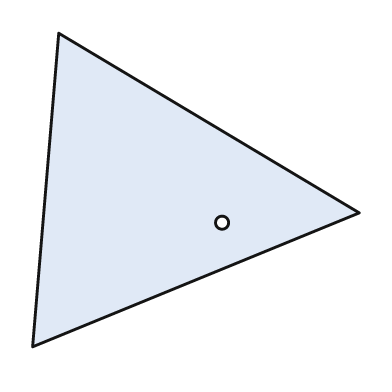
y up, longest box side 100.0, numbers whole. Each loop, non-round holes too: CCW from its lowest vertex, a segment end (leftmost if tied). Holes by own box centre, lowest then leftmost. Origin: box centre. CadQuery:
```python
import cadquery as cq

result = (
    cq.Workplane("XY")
    .moveTo(-50.0, -48.0)
    .lineTo(50.0, -7.0)
    .lineTo(-42.0, 48.0)
    .close()
    .moveTo(8.0, -10.0)
    .circle(2.0)
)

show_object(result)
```